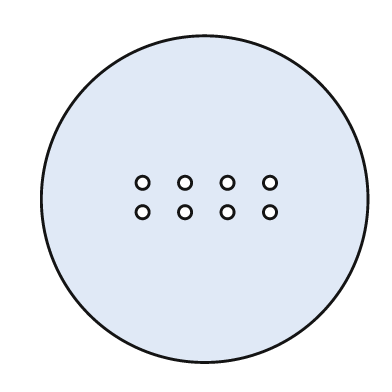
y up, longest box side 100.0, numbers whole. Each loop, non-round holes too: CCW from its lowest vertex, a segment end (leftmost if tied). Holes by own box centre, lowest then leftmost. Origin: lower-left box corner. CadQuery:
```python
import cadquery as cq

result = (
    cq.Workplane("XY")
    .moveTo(50.0, 50.0)
    .circle(50.0)
    .moveTo(31.0, 46.0)
    .circle(2.0)
    .moveTo(44.0, 46.0)
    .circle(2.0)
    .moveTo(57.0, 46.0)
    .circle(2.0)
    .moveTo(70.0, 46.0)
    .circle(2.0)
    .moveTo(31.0, 55.0)
    .circle(2.0)
    .moveTo(44.0, 55.0)
    .circle(2.0)
    .moveTo(57.0, 55.0)
    .circle(2.0)
    .moveTo(70.0, 55.0)
    .circle(2.0)
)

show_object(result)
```